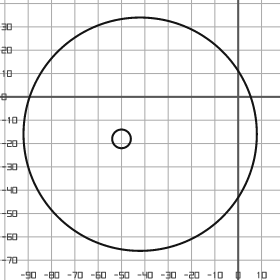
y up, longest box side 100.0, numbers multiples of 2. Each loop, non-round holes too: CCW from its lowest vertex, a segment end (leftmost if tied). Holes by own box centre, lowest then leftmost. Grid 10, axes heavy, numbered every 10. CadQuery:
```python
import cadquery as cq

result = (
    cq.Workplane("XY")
    .moveTo(-42.0, -16.0)
    .circle(50.0)
    .moveTo(-50.0, -18.0)
    .circle(4.0)
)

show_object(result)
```